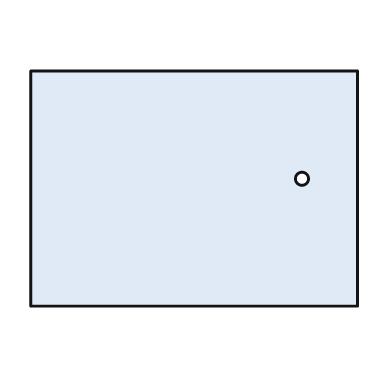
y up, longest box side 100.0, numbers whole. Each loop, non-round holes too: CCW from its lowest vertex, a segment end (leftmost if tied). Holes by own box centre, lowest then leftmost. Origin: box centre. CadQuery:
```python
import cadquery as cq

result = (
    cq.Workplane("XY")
    .moveTo(-50.0, -36.0)
    .lineTo(50.0, -36.0)
    .lineTo(50.0, 36.0)
    .lineTo(-50.0, 36.0)
    .close()
    .moveTo(33.0, 3.0)
    .circle(2.0)
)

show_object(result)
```